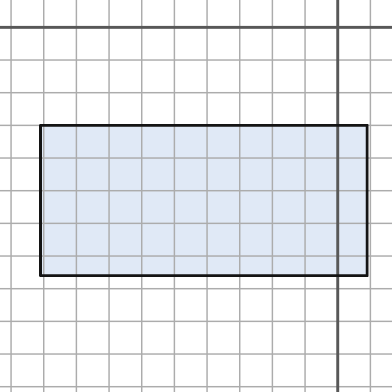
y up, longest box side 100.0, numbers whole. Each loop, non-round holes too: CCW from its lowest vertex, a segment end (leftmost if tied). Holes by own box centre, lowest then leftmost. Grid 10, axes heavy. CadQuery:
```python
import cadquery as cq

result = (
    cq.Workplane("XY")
    .moveTo(-91.0, -76.0)
    .lineTo(9.0, -76.0)
    .lineTo(9.0, -30.0)
    .lineTo(-91.0, -30.0)
    .close()
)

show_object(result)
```